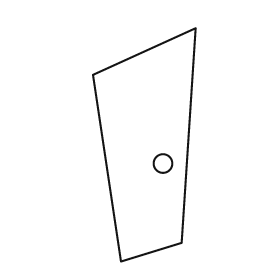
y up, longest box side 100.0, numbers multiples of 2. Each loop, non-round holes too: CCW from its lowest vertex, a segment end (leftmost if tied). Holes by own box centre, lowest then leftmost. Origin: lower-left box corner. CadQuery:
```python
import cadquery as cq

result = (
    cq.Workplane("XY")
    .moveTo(12.0, 0.0)
    .lineTo(38.0, 8.0)
    .lineTo(44.0, 100.0)
    .lineTo(0.0, 80.0)
    .close()
    .moveTo(30.0, 42.0)
    .circle(4.0)
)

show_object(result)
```